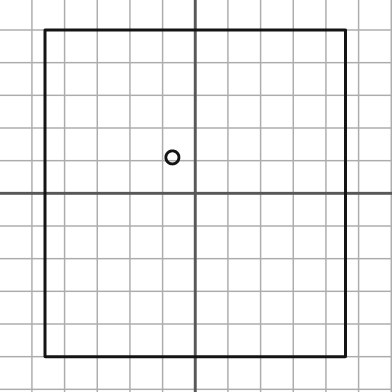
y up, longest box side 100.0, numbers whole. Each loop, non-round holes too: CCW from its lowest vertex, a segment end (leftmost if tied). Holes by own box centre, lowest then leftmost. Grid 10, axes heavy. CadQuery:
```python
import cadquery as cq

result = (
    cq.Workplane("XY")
    .moveTo(-46.0, -50.0)
    .lineTo(46.0, -50.0)
    .lineTo(46.0, 50.0)
    .lineTo(-46.0, 50.0)
    .close()
    .moveTo(-7.0, 11.0)
    .circle(2.0)
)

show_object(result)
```